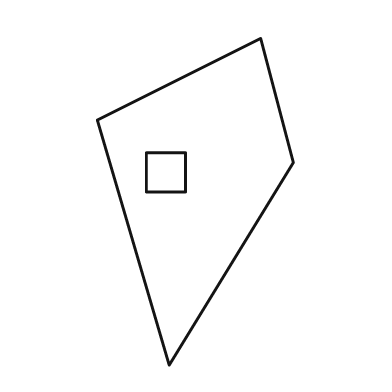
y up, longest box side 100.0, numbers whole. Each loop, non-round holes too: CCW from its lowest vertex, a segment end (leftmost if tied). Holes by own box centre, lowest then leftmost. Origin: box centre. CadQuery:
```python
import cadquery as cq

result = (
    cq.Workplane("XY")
    .moveTo(-8.0, -50.0)
    .lineTo(30.0, 12.0)
    .lineTo(20.0, 50.0)
    .lineTo(-30.0, 25.0)
    .close()
    .moveTo(-15.0, 3.0)
    .lineTo(-3.0, 3.0)
    .lineTo(-3.0, 15.0)
    .lineTo(-15.0, 15.0)
    .close()
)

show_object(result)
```